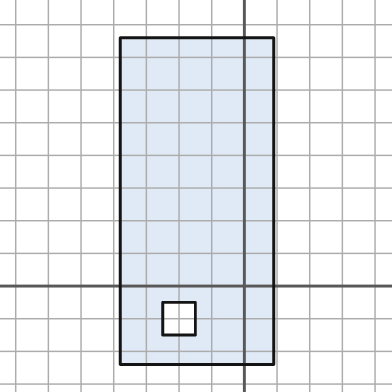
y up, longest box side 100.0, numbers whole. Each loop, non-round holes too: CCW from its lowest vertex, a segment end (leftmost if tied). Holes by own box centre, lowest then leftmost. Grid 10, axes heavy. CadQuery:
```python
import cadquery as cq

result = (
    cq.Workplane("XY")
    .moveTo(-38.0, -24.0)
    .lineTo(9.0, -24.0)
    .lineTo(9.0, 76.0)
    .lineTo(-38.0, 76.0)
    .close()
    .moveTo(-25.0, -15.0)
    .lineTo(-15.0, -15.0)
    .lineTo(-15.0, -5.0)
    .lineTo(-25.0, -5.0)
    .close()
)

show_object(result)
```